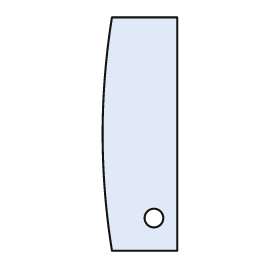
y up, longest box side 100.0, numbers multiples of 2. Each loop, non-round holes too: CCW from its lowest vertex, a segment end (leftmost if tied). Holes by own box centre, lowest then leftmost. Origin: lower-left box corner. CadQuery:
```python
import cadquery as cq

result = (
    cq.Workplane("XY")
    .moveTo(4.0, 0.0)
    .lineTo(32.0, 0.0)
    .lineTo(32.0, 100.0)
    .lineTo(4.0, 100.0)
    .threePointArc((0.0, 50.0), (4.0, 0.0))
    .close()
    .moveTo(22.0, 14.0)
    .circle(4.0)
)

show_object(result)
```